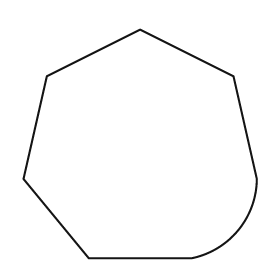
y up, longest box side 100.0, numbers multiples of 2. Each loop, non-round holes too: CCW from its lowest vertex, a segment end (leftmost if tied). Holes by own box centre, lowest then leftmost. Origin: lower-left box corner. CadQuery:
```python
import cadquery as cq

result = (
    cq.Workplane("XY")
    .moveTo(28.0, 0.0)
    .lineTo(72.0, 0.0)
    .threePointArc((92.0, 12.0), (100.0, 34.0))
    .lineTo(90.0, 78.0)
    .lineTo(50.0, 98.0)
    .lineTo(10.0, 78.0)
    .lineTo(0.0, 34.0)
    .close()
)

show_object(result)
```